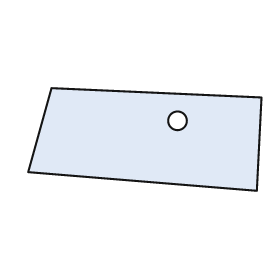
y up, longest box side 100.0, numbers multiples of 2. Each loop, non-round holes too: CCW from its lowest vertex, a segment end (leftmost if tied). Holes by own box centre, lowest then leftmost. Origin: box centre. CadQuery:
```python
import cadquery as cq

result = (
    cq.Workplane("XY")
    .moveTo(48.0, -22.0)
    .lineTo(50.0, 18.0)
    .lineTo(-40.0, 22.0)
    .lineTo(-50.0, -14.0)
    .close()
    .moveTo(14.0, 8.0)
    .circle(4.0)
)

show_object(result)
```